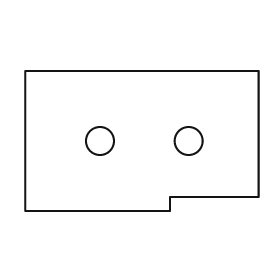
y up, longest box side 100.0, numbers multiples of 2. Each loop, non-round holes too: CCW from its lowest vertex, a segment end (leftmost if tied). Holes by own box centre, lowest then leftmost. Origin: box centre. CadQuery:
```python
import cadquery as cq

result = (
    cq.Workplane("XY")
    .moveTo(-50.0, -30.0)
    .lineTo(12.0, -30.0)
    .lineTo(12.0, -24.0)
    .lineTo(50.0, -24.0)
    .lineTo(50.0, 30.0)
    .lineTo(-50.0, 30.0)
    .close()
    .moveTo(-18.0, 0.0)
    .circle(6.0)
    .moveTo(20.0, 0.0)
    .circle(6.0)
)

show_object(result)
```